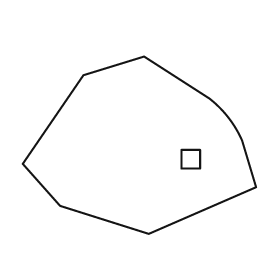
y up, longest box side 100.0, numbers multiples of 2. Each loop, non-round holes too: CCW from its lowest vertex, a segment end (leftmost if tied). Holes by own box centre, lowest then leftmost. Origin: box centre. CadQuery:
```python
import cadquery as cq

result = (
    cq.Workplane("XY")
    .moveTo(4.0, -38.0)
    .lineTo(50.0, -18.0)
    .lineTo(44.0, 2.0)
    .threePointArc((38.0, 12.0), (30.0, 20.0))
    .lineTo(2.0, 38.0)
    .lineTo(-24.0, 30.0)
    .lineTo(-50.0, -8.0)
    .lineTo(-34.0, -26.0)
    .close()
    .moveTo(18.0, -10.0)
    .lineTo(26.0, -10.0)
    .lineTo(26.0, -2.0)
    .lineTo(18.0, -2.0)
    .close()
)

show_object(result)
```